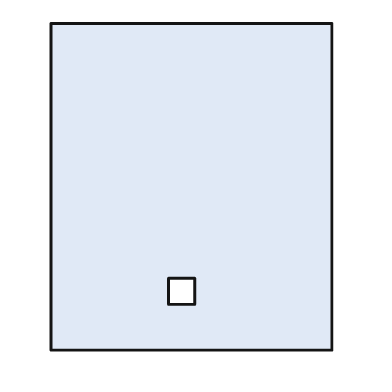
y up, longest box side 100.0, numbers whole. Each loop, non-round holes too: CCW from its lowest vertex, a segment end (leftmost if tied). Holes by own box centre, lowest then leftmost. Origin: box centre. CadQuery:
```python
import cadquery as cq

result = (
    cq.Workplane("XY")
    .moveTo(-43.0, -50.0)
    .lineTo(43.0, -50.0)
    .lineTo(43.0, 50.0)
    .lineTo(-43.0, 50.0)
    .close()
    .moveTo(-7.0, -36.0)
    .lineTo(1.0, -36.0)
    .lineTo(1.0, -28.0)
    .lineTo(-7.0, -28.0)
    .close()
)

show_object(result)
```